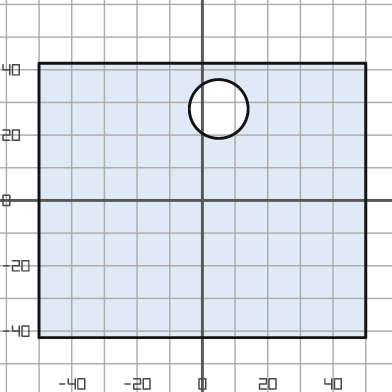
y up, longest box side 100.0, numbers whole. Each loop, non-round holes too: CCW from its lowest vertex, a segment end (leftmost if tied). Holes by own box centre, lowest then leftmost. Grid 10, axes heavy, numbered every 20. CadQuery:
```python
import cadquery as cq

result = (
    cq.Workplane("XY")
    .moveTo(-50.0, -42.0)
    .lineTo(50.0, -42.0)
    .lineTo(50.0, 42.0)
    .lineTo(-50.0, 42.0)
    .close()
    .moveTo(5.0, 28.0)
    .circle(9.0)
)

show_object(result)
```